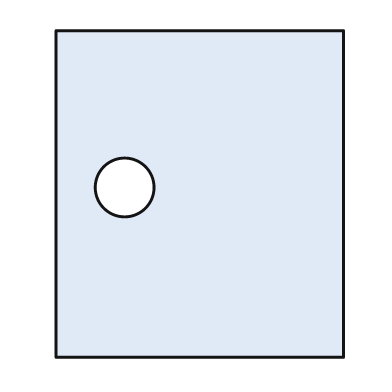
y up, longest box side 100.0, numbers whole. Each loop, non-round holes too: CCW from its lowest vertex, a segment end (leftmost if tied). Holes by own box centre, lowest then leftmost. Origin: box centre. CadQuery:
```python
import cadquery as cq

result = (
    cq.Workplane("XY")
    .moveTo(-44.0, -50.0)
    .lineTo(44.0, -50.0)
    .lineTo(44.0, 50.0)
    .lineTo(-44.0, 50.0)
    .close()
    .moveTo(-23.0, 2.0)
    .circle(9.0)
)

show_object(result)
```